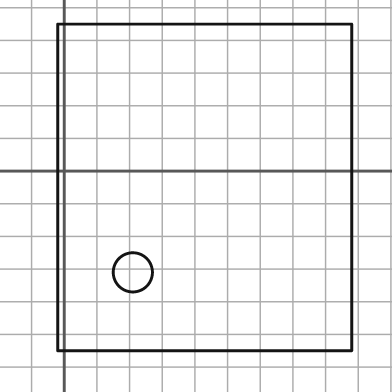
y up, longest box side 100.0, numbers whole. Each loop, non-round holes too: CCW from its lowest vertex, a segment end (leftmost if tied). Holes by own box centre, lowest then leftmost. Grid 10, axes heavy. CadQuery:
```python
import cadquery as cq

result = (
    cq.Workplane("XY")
    .moveTo(-2.0, -55.0)
    .lineTo(88.0, -55.0)
    .lineTo(88.0, 45.0)
    .lineTo(-2.0, 45.0)
    .close()
    .moveTo(21.0, -31.0)
    .circle(6.0)
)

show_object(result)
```